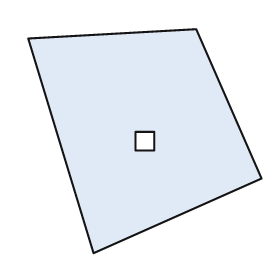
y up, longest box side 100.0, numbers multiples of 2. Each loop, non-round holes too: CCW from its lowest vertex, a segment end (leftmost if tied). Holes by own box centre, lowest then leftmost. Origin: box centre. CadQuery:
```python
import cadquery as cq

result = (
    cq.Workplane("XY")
    .moveTo(-22.0, -48.0)
    .lineTo(50.0, -16.0)
    .lineTo(22.0, 48.0)
    .lineTo(-50.0, 44.0)
    .close()
    .moveTo(-4.0, -4.0)
    .lineTo(4.0, -4.0)
    .lineTo(4.0, 4.0)
    .lineTo(-4.0, 4.0)
    .close()
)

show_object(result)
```